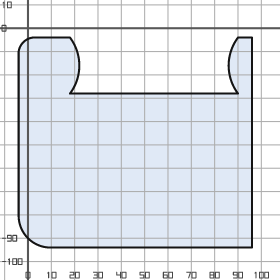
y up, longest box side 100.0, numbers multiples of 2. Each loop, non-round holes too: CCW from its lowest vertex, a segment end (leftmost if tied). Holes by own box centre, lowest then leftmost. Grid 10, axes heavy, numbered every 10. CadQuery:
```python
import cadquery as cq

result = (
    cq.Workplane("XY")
    .moveTo(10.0, -94.0)
    .lineTo(96.0, -94.0)
    .lineTo(96.0, -4.0)
    .lineTo(90.0, -4.0)
    .threePointArc((86.0, -16.0), (90.0, -28.0))
    .lineTo(18.0, -28.0)
    .threePointArc((22.0, -16.0), (18.0, -4.0))
    .lineTo(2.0, -4.0)
    .threePointArc((-2.0, -6.0), (-4.0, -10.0))
    .lineTo(-4.0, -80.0)
    .threePointArc((0.0, -90.0), (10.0, -94.0))
    .close()
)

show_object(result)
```